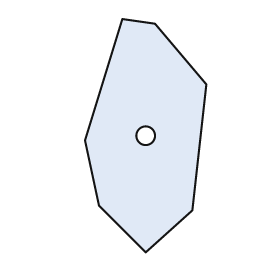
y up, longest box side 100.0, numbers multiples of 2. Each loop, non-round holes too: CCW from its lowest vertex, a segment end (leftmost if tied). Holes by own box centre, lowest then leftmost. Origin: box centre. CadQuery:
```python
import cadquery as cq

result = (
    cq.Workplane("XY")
    .moveTo(0.0, -50.0)
    .lineTo(20.0, -32.0)
    .lineTo(26.0, 22.0)
    .lineTo(4.0, 48.0)
    .lineTo(-10.0, 50.0)
    .lineTo(-26.0, -2.0)
    .lineTo(-20.0, -30.0)
    .close()
    .moveTo(0.0, 0.0)
    .circle(4.0)
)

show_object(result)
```